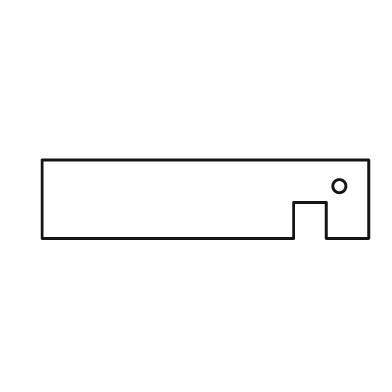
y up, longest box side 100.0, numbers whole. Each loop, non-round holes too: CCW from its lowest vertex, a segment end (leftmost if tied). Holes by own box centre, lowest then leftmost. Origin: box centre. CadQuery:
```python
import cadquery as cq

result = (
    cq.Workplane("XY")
    .moveTo(-50.0, -12.0)
    .lineTo(27.0, -12.0)
    .lineTo(27.0, -1.0)
    .lineTo(37.0, -1.0)
    .lineTo(37.0, -12.0)
    .lineTo(50.0, -12.0)
    .lineTo(50.0, 12.0)
    .lineTo(-50.0, 12.0)
    .close()
    .moveTo(41.0, 4.0)
    .circle(2.0)
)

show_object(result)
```